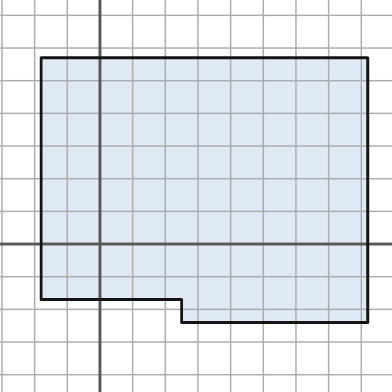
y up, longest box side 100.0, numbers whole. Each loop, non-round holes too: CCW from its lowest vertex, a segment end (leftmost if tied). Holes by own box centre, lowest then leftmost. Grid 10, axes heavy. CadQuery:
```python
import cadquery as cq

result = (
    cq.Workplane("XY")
    .moveTo(25.0, -24.0)
    .lineTo(82.0, -24.0)
    .lineTo(82.0, 57.0)
    .lineTo(-18.0, 57.0)
    .lineTo(-18.0, -17.0)
    .lineTo(25.0, -17.0)
    .close()
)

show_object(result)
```